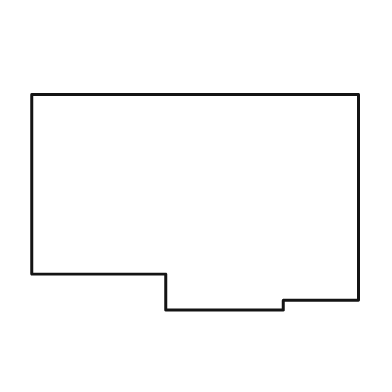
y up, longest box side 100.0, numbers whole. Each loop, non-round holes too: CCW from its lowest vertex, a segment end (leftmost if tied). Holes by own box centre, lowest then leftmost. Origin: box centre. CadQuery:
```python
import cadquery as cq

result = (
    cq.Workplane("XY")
    .moveTo(-9.0, -33.0)
    .lineTo(27.0, -33.0)
    .lineTo(27.0, -30.0)
    .lineTo(50.0, -30.0)
    .lineTo(50.0, 33.0)
    .lineTo(-50.0, 33.0)
    .lineTo(-50.0, -22.0)
    .lineTo(-9.0, -22.0)
    .close()
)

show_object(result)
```